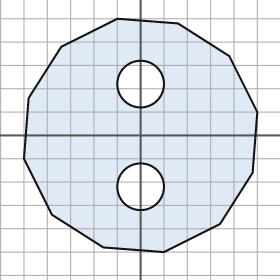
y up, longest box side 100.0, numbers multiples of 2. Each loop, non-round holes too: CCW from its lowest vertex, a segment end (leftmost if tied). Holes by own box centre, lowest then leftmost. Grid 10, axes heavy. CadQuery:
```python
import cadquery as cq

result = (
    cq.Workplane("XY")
    .moveTo(10.0, -50.0)
    .lineTo(34.0, -38.0)
    .lineTo(48.0, -16.0)
    .lineTo(50.0, 10.0)
    .lineTo(38.0, 34.0)
    .lineTo(16.0, 48.0)
    .lineTo(-10.0, 50.0)
    .lineTo(-34.0, 38.0)
    .lineTo(-48.0, 16.0)
    .lineTo(-50.0, -10.0)
    .lineTo(-38.0, -34.0)
    .lineTo(-16.0, -48.0)
    .close()
    .moveTo(0.0, -22.0)
    .circle(10.0)
    .moveTo(0.0, 22.0)
    .circle(10.0)
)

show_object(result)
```